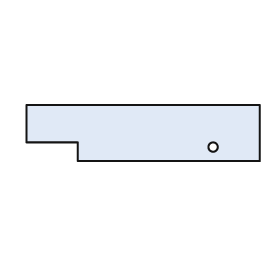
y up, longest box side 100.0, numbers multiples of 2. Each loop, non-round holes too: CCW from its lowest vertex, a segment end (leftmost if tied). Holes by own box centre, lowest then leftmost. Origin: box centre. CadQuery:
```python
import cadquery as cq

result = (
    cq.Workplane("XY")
    .moveTo(-28.0, -12.0)
    .lineTo(50.0, -12.0)
    .lineTo(50.0, 12.0)
    .lineTo(-50.0, 12.0)
    .lineTo(-50.0, -4.0)
    .lineTo(-28.0, -4.0)
    .close()
    .moveTo(30.0, -6.0)
    .circle(2.0)
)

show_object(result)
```